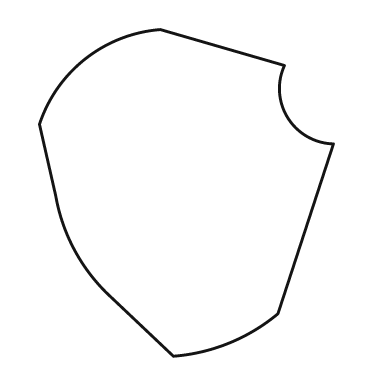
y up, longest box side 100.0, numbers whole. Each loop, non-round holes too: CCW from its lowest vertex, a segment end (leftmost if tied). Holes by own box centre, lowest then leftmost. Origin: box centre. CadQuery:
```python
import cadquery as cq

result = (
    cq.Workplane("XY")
    .moveTo(-4.0, -50.0)
    .threePointArc((13.0, -46.0), (28.0, -37.0))
    .lineTo(45.0, 15.0)
    .threePointArc((31.0, 23.0), (30.0, 39.0))
    .lineTo(-8.0, 50.0)
    .threePointArc((-31.0, 41.0), (-45.0, 21.0))
    .lineTo(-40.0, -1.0)
    .threePointArc((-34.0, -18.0), (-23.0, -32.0))
    .close()
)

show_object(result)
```